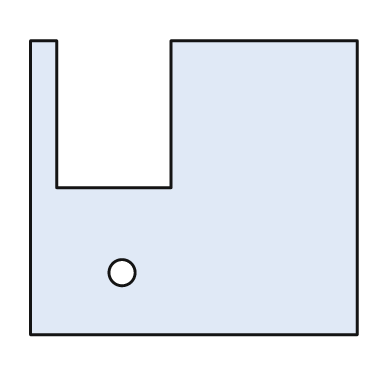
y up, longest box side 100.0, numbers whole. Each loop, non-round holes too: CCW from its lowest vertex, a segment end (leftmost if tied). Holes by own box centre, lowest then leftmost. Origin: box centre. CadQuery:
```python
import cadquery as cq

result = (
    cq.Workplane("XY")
    .moveTo(-50.0, -45.0)
    .lineTo(50.0, -45.0)
    .lineTo(50.0, 45.0)
    .lineTo(-7.0, 45.0)
    .lineTo(-7.0, 0.0)
    .lineTo(-42.0, 0.0)
    .lineTo(-42.0, 45.0)
    .lineTo(-50.0, 45.0)
    .close()
    .moveTo(-22.0, -26.0)
    .circle(4.0)
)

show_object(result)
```